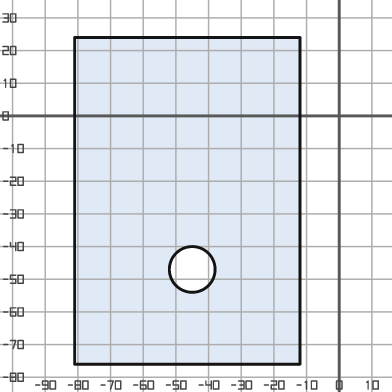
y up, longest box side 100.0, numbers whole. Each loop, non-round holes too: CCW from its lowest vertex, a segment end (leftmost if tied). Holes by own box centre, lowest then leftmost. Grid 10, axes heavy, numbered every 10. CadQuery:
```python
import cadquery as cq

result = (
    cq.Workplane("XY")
    .moveTo(-81.0, -76.0)
    .lineTo(-12.0, -76.0)
    .lineTo(-12.0, 24.0)
    .lineTo(-81.0, 24.0)
    .close()
    .moveTo(-45.0, -47.0)
    .circle(7.0)
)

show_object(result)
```